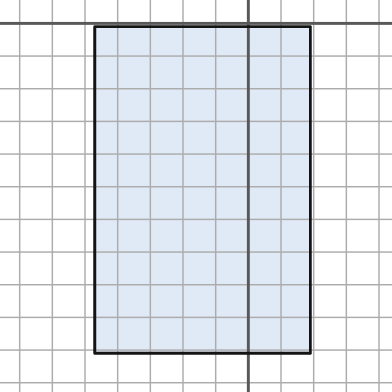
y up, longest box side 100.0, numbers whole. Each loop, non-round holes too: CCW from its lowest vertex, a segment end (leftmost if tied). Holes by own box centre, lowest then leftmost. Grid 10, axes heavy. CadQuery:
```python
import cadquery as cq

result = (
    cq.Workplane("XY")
    .moveTo(-47.0, -101.0)
    .lineTo(19.0, -101.0)
    .lineTo(19.0, -1.0)
    .lineTo(-47.0, -1.0)
    .close()
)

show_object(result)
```